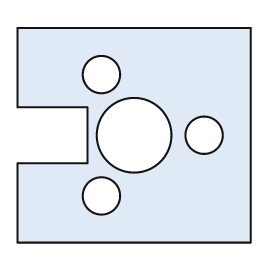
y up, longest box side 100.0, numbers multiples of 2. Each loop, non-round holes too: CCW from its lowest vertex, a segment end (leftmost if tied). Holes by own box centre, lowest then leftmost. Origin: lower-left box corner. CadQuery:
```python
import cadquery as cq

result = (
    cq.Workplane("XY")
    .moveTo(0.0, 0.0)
    .lineTo(100.0, 0.0)
    .lineTo(100.0, 92.0)
    .lineTo(0.0, 92.0)
    .lineTo(0.0, 58.0)
    .lineTo(30.0, 58.0)
    .lineTo(30.0, 34.0)
    .lineTo(0.0, 34.0)
    .close()
    .moveTo(36.0, 20.0)
    .circle(8.0)
    .moveTo(50.0, 46.0)
    .circle(16.0)
    .moveTo(80.0, 46.0)
    .circle(8.0)
    .moveTo(36.0, 72.0)
    .circle(8.0)
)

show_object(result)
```